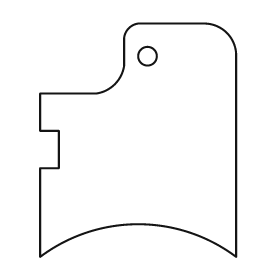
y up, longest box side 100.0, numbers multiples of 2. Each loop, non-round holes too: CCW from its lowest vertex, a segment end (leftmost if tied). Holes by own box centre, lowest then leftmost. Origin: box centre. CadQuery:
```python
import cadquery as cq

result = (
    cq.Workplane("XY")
    .moveTo(-42.0, -50.0)
    .threePointArc((0.0, -36.0), (42.0, -50.0))
    .lineTo(42.0, 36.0)
    .threePointArc((38.0, 46.0), (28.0, 50.0))
    .lineTo(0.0, 50.0)
    .threePointArc((-4.0, 48.0), (-6.0, 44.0))
    .lineTo(-6.0, 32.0)
    .threePointArc((-10.0, 24.0), (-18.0, 20.0))
    .lineTo(-42.0, 20.0)
    .lineTo(-42.0, 4.0)
    .lineTo(-34.0, 4.0)
    .lineTo(-34.0, -12.0)
    .lineTo(-42.0, -12.0)
    .close()
    .moveTo(4.0, 36.0)
    .circle(4.0)
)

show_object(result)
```